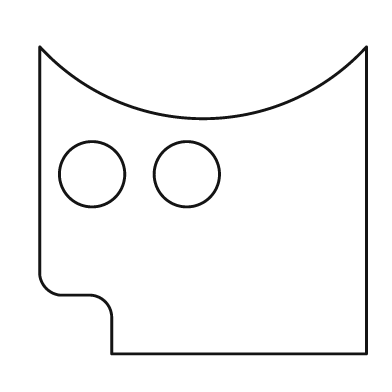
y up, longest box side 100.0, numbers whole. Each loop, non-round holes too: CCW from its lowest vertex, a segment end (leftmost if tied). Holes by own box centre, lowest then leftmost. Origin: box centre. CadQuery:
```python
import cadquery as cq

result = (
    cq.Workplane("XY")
    .moveTo(-28.0, -47.0)
    .lineTo(50.0, -47.0)
    .lineTo(50.0, 47.0)
    .threePointArc((0.0, 25.0), (-50.0, 47.0))
    .lineTo(-50.0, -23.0)
    .threePointArc((-48.0, -27.0), (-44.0, -29.0))
    .lineTo(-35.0, -29.0)
    .threePointArc((-30.0, -31.0), (-28.0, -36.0))
    .close()
    .moveTo(-34.0, 8.0)
    .circle(10.0)
    .moveTo(-5.0, 8.0)
    .circle(10.0)
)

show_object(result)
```